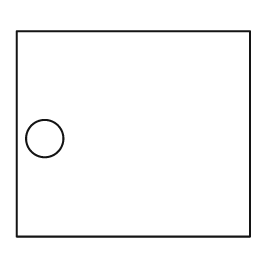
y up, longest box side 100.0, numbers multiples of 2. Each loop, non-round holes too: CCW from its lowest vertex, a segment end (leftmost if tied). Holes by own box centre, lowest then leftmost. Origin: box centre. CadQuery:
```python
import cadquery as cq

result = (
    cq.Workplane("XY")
    .moveTo(-50.0, -44.0)
    .lineTo(50.0, -44.0)
    .lineTo(50.0, 44.0)
    .lineTo(-50.0, 44.0)
    .close()
    .moveTo(-38.0, -2.0)
    .circle(8.0)
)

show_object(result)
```